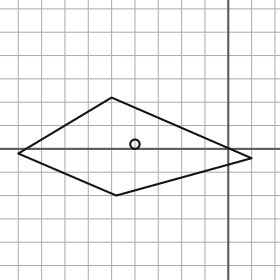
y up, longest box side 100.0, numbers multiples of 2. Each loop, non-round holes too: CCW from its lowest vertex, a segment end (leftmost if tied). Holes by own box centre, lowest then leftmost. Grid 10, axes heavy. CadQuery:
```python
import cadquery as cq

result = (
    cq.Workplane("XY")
    .moveTo(-48.0, -20.0)
    .lineTo(10.0, -4.0)
    .lineTo(-50.0, 22.0)
    .lineTo(-90.0, -2.0)
    .close()
    .moveTo(-40.0, 2.0)
    .circle(2.0)
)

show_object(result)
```